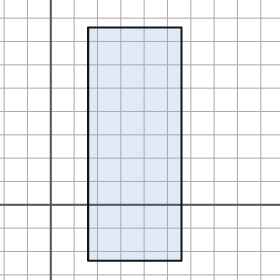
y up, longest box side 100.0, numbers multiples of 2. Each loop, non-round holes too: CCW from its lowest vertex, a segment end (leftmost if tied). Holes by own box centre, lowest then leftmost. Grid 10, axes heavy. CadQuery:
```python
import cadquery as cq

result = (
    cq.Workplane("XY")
    .moveTo(16.0, -24.0)
    .lineTo(56.0, -24.0)
    .lineTo(56.0, 76.0)
    .lineTo(16.0, 76.0)
    .close()
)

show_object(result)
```